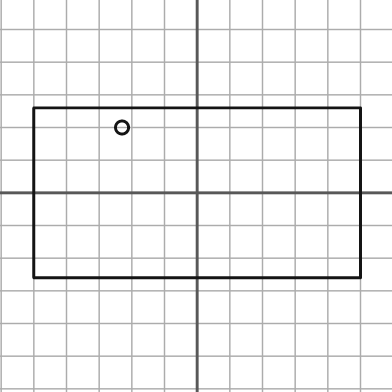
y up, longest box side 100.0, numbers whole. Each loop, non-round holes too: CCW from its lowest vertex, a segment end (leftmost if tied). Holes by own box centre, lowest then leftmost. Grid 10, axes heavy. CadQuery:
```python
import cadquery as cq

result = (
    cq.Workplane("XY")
    .moveTo(-50.0, -26.0)
    .lineTo(50.0, -26.0)
    .lineTo(50.0, 26.0)
    .lineTo(-50.0, 26.0)
    .close()
    .moveTo(-23.0, 20.0)
    .circle(2.0)
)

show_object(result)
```